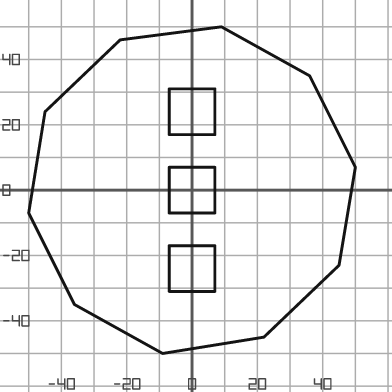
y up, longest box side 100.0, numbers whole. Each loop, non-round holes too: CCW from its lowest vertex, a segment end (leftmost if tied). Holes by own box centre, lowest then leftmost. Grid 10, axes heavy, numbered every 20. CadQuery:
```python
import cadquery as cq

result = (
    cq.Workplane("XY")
    .moveTo(-9.0, -50.0)
    .lineTo(22.0, -45.0)
    .lineTo(45.0, -23.0)
    .lineTo(50.0, 7.0)
    .lineTo(36.0, 35.0)
    .lineTo(9.0, 50.0)
    .lineTo(-22.0, 46.0)
    .lineTo(-45.0, 24.0)
    .lineTo(-50.0, -7.0)
    .lineTo(-36.0, -35.0)
    .close()
    .moveTo(-7.0, -31.0)
    .lineTo(7.0, -31.0)
    .lineTo(7.0, -17.0)
    .lineTo(-7.0, -17.0)
    .close()
    .moveTo(-7.0, -7.0)
    .lineTo(7.0, -7.0)
    .lineTo(7.0, 7.0)
    .lineTo(-7.0, 7.0)
    .close()
    .moveTo(-7.0, 17.0)
    .lineTo(7.0, 17.0)
    .lineTo(7.0, 31.0)
    .lineTo(-7.0, 31.0)
    .close()
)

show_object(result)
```